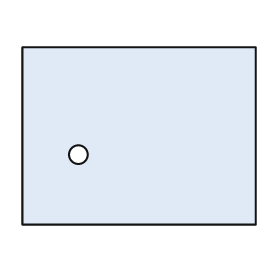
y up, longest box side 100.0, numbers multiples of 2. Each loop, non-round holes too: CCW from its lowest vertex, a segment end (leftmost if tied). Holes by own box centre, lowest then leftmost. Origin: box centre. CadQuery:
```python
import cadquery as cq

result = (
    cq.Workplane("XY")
    .moveTo(-50.0, -38.0)
    .lineTo(50.0, -38.0)
    .lineTo(50.0, 38.0)
    .lineTo(-50.0, 38.0)
    .close()
    .moveTo(-26.0, -8.0)
    .circle(4.0)
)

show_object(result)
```